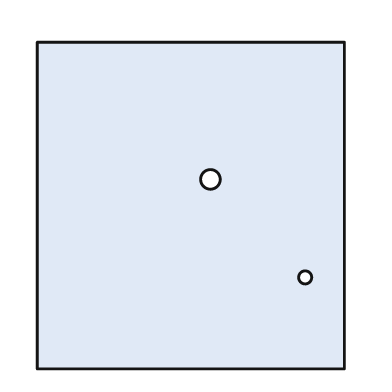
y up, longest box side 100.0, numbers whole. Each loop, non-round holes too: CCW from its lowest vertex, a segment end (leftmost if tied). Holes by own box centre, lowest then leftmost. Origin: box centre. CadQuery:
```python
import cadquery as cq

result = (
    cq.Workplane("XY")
    .moveTo(-47.0, -50.0)
    .lineTo(47.0, -50.0)
    .lineTo(47.0, 50.0)
    .lineTo(-47.0, 50.0)
    .close()
    .moveTo(35.0, -22.0)
    .circle(2.0)
    .moveTo(6.0, 8.0)
    .circle(3.0)
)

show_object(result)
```